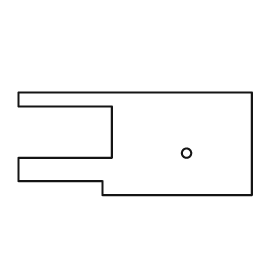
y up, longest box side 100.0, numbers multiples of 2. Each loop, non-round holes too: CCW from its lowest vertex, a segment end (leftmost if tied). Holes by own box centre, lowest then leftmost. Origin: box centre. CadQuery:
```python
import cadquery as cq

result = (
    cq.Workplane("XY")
    .moveTo(-14.0, -22.0)
    .lineTo(50.0, -22.0)
    .lineTo(50.0, 22.0)
    .lineTo(-50.0, 22.0)
    .lineTo(-50.0, 16.0)
    .lineTo(-10.0, 16.0)
    .lineTo(-10.0, -6.0)
    .lineTo(-50.0, -6.0)
    .lineTo(-50.0, -16.0)
    .lineTo(-14.0, -16.0)
    .close()
    .moveTo(22.0, -4.0)
    .circle(2.0)
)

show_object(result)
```